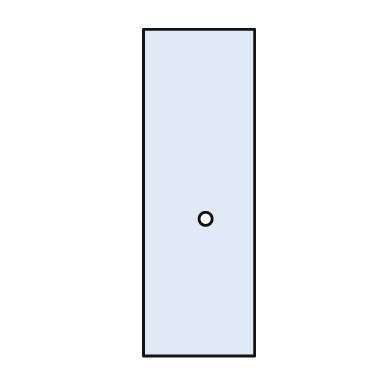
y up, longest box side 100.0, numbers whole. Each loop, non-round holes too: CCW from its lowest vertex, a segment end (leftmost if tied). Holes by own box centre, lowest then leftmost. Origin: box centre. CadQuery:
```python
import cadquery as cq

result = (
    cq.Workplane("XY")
    .moveTo(-17.0, -50.0)
    .lineTo(17.0, -50.0)
    .lineTo(17.0, 50.0)
    .lineTo(-17.0, 50.0)
    .close()
    .moveTo(2.0, -8.0)
    .circle(2.0)
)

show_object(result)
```